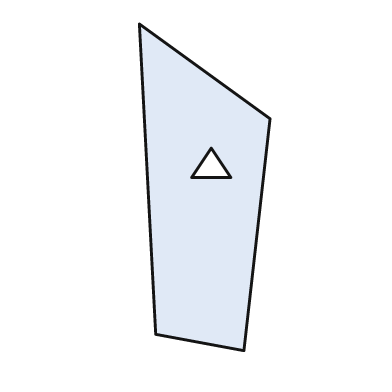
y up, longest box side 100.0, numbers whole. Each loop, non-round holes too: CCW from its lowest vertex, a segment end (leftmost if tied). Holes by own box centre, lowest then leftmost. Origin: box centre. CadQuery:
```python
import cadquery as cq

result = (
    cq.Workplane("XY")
    .moveTo(12.0, -50.0)
    .lineTo(20.0, 21.0)
    .lineTo(-20.0, 50.0)
    .lineTo(-15.0, -45.0)
    .close()
    .moveTo(-4.0, 3.0)
    .lineTo(8.0, 3.0)
    .lineTo(2.0, 12.0)
    .close()
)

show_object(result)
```